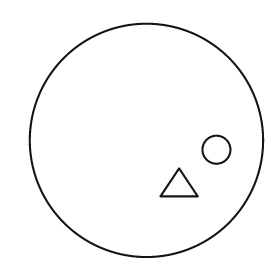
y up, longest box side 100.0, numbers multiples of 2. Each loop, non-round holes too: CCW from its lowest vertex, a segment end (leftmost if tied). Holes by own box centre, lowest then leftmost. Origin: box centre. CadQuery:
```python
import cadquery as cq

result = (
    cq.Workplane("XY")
    .moveTo(0.0, 0.0)
    .circle(50.0)
    .moveTo(6.0, -24.0)
    .lineTo(22.0, -24.0)
    .lineTo(14.0, -12.0)
    .close()
    .moveTo(30.0, -4.0)
    .circle(6.0)
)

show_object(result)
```